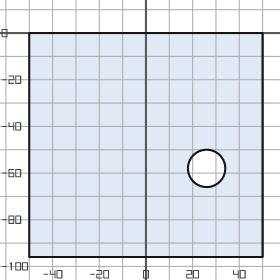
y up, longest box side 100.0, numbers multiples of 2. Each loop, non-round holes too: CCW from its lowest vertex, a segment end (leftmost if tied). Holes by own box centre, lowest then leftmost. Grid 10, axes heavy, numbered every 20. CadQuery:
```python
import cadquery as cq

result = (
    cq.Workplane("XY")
    .moveTo(-50.0, -96.0)
    .lineTo(50.0, -96.0)
    .lineTo(50.0, 0.0)
    .lineTo(-50.0, 0.0)
    .close()
    .moveTo(26.0, -58.0)
    .circle(8.0)
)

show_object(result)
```